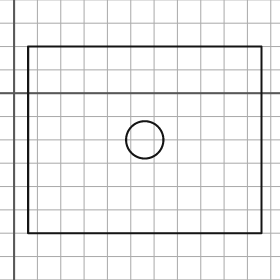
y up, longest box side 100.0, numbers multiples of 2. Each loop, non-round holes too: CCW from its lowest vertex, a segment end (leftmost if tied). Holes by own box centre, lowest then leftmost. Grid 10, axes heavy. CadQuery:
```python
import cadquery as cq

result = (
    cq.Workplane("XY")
    .moveTo(6.0, -60.0)
    .lineTo(106.0, -60.0)
    .lineTo(106.0, 20.0)
    .lineTo(6.0, 20.0)
    .close()
    .moveTo(56.0, -20.0)
    .circle(8.0)
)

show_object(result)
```